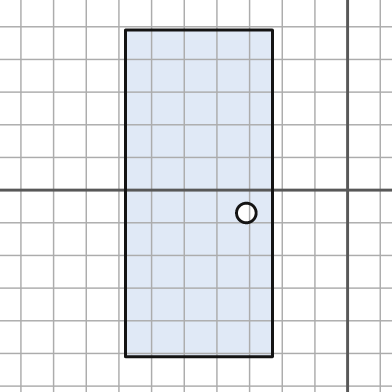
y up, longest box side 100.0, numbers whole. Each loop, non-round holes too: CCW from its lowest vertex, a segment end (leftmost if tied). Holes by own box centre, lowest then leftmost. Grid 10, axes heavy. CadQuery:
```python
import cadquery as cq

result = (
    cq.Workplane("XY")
    .moveTo(-68.0, -51.0)
    .lineTo(-23.0, -51.0)
    .lineTo(-23.0, 49.0)
    .lineTo(-68.0, 49.0)
    .close()
    .moveTo(-31.0, -7.0)
    .circle(3.0)
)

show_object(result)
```